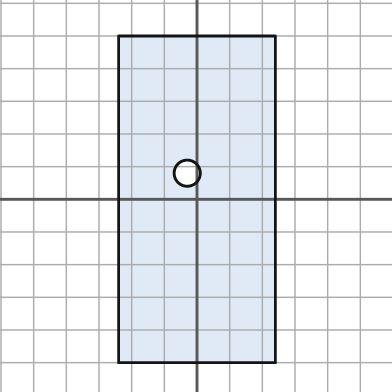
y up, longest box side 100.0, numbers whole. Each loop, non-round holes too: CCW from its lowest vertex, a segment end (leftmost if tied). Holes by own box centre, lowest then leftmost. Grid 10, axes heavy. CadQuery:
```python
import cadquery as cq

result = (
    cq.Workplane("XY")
    .moveTo(-24.0, -50.0)
    .lineTo(24.0, -50.0)
    .lineTo(24.0, 50.0)
    .lineTo(-24.0, 50.0)
    .close()
    .moveTo(-3.0, 8.0)
    .circle(4.0)
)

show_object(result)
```